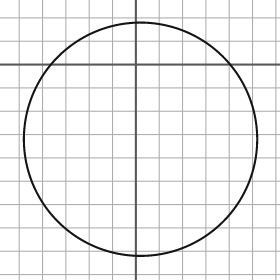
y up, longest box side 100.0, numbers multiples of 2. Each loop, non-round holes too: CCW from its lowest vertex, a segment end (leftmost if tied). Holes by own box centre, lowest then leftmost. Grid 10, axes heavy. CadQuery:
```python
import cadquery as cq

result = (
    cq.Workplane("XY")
    .moveTo(2.0, -32.0)
    .circle(50.0)
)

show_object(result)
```